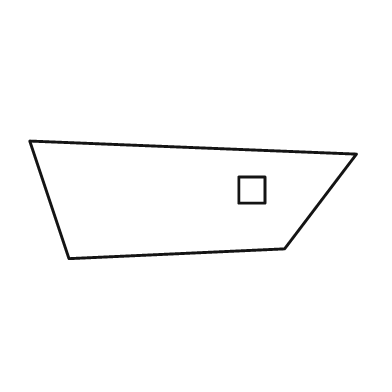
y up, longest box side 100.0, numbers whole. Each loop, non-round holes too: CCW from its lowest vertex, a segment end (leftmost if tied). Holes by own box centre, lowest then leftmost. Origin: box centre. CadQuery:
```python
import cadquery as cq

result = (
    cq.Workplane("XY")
    .moveTo(-38.0, -18.0)
    .lineTo(28.0, -15.0)
    .lineTo(50.0, 14.0)
    .lineTo(-50.0, 18.0)
    .close()
    .moveTo(14.0, -1.0)
    .lineTo(22.0, -1.0)
    .lineTo(22.0, 7.0)
    .lineTo(14.0, 7.0)
    .close()
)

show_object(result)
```